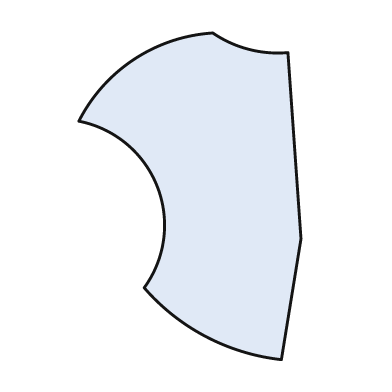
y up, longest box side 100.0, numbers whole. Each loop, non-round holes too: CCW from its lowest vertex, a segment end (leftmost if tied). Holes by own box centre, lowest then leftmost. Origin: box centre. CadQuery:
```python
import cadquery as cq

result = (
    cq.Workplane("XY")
    .moveTo(28.0, -50.0)
    .lineTo(34.0, -13.0)
    .lineTo(30.0, 44.0)
    .threePointArc((18.0, 45.0), (7.0, 50.0))
    .threePointArc((-17.0, 42.0), (-34.0, 23.0))
    .threePointArc((-10.0, 3.0), (-14.0, -28.0))
    .threePointArc((5.0, -43.0), (28.0, -50.0))
    .close()
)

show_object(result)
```